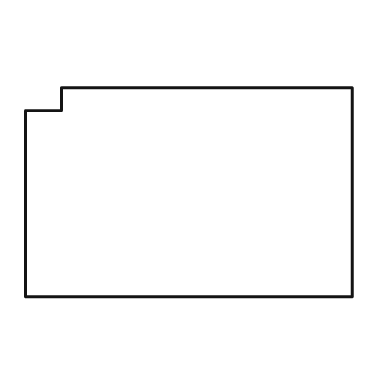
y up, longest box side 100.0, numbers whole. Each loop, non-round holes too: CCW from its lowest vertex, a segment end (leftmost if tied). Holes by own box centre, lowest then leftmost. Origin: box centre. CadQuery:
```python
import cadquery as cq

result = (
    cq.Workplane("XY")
    .moveTo(-50.0, -32.0)
    .lineTo(50.0, -32.0)
    .lineTo(50.0, 32.0)
    .lineTo(-39.0, 32.0)
    .lineTo(-39.0, 25.0)
    .lineTo(-50.0, 25.0)
    .close()
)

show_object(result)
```